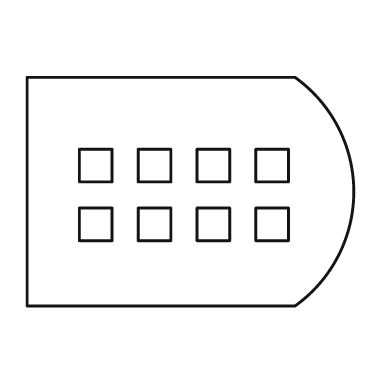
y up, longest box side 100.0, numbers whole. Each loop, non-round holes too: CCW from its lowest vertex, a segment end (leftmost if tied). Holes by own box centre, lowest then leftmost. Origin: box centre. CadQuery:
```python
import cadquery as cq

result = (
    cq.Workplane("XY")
    .moveTo(-50.0, -35.0)
    .lineTo(32.0, -35.0)
    .threePointArc((50.0, 0.0), (32.0, 35.0))
    .lineTo(-50.0, 35.0)
    .close()
    .moveTo(-34.0, -15.0)
    .lineTo(-24.0, -15.0)
    .lineTo(-24.0, -5.0)
    .lineTo(-34.0, -5.0)
    .close()
    .moveTo(-16.0, -15.0)
    .lineTo(-6.0, -15.0)
    .lineTo(-6.0, -5.0)
    .lineTo(-16.0, -5.0)
    .close()
    .moveTo(2.0, -15.0)
    .lineTo(12.0, -15.0)
    .lineTo(12.0, -5.0)
    .lineTo(2.0, -5.0)
    .close()
    .moveTo(20.0, -15.0)
    .lineTo(30.0, -15.0)
    .lineTo(30.0, -5.0)
    .lineTo(20.0, -5.0)
    .close()
    .moveTo(-34.0, 3.0)
    .lineTo(-24.0, 3.0)
    .lineTo(-24.0, 13.0)
    .lineTo(-34.0, 13.0)
    .close()
    .moveTo(-16.0, 3.0)
    .lineTo(-6.0, 3.0)
    .lineTo(-6.0, 13.0)
    .lineTo(-16.0, 13.0)
    .close()
    .moveTo(2.0, 3.0)
    .lineTo(12.0, 3.0)
    .lineTo(12.0, 13.0)
    .lineTo(2.0, 13.0)
    .close()
    .moveTo(20.0, 3.0)
    .lineTo(30.0, 3.0)
    .lineTo(30.0, 13.0)
    .lineTo(20.0, 13.0)
    .close()
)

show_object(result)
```